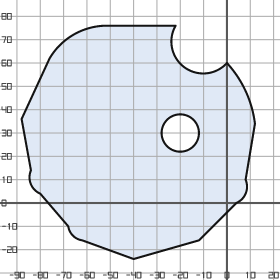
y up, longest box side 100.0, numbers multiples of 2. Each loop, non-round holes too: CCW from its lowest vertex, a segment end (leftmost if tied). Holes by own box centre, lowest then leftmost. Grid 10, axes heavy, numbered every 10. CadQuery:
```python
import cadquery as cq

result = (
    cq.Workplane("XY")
    .moveTo(-40.0, -24.0)
    .lineTo(-12.0, -16.0)
    .lineTo(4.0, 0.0)
    .threePointArc((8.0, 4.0), (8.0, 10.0))
    .lineTo(12.0, 34.0)
    .threePointArc((8.0, 48.0), (0.0, 60.0))
    .threePointArc((-18.0, 58.0), (-22.0, 76.0))
    .lineTo(-52.0, 76.0)
    .threePointArc((-66.0, 72.0), (-76.0, 62.0))
    .lineTo(-88.0, 36.0)
    .lineTo(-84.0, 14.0)
    .threePointArc((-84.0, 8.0), (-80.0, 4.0))
    .lineTo(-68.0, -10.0)
    .threePointArc((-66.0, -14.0), (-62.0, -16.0))
    .close()
    .moveTo(-20.0, 30.0)
    .circle(8.0)
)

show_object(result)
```